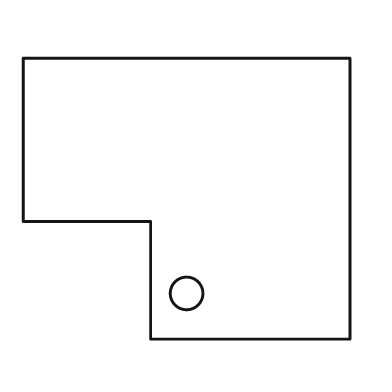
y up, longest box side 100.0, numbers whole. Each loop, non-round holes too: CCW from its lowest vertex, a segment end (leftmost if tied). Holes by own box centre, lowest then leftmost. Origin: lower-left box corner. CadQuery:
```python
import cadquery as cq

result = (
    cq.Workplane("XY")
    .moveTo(39.0, 0.0)
    .lineTo(100.0, 0.0)
    .lineTo(100.0, 86.0)
    .lineTo(0.0, 86.0)
    .lineTo(0.0, 36.0)
    .lineTo(39.0, 36.0)
    .close()
    .moveTo(50.0, 14.0)
    .circle(5.0)
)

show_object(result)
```